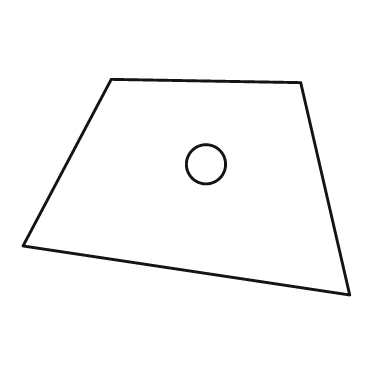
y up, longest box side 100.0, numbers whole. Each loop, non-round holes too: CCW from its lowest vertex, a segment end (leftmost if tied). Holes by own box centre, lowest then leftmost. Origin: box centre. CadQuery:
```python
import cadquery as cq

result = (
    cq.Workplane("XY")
    .moveTo(50.0, -33.0)
    .lineTo(35.0, 32.0)
    .lineTo(-23.0, 33.0)
    .lineTo(-50.0, -18.0)
    .close()
    .moveTo(6.0, 7.0)
    .circle(6.0)
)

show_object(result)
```